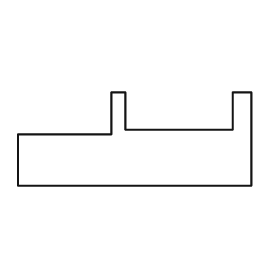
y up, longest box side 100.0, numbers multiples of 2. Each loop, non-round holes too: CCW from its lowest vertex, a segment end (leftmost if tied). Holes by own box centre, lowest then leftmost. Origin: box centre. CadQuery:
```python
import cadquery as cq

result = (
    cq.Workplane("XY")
    .moveTo(-50.0, -20.0)
    .lineTo(50.0, -20.0)
    .lineTo(50.0, 20.0)
    .lineTo(42.0, 20.0)
    .lineTo(42.0, 4.0)
    .lineTo(-4.0, 4.0)
    .lineTo(-4.0, 20.0)
    .lineTo(-10.0, 20.0)
    .lineTo(-10.0, 2.0)
    .lineTo(-50.0, 2.0)
    .close()
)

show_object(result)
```